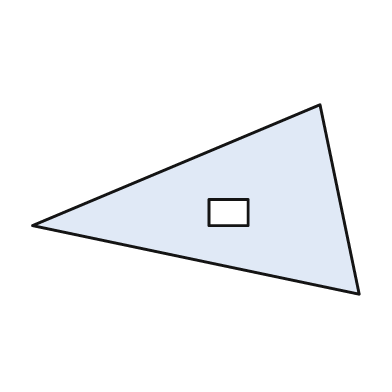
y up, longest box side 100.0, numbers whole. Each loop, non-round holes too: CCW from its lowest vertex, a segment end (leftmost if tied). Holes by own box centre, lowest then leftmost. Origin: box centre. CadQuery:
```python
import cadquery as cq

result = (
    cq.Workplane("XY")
    .moveTo(50.0, -29.0)
    .lineTo(38.0, 29.0)
    .lineTo(-50.0, -8.0)
    .close()
    .moveTo(4.0, -8.0)
    .lineTo(16.0, -8.0)
    .lineTo(16.0, 0.0)
    .lineTo(4.0, 0.0)
    .close()
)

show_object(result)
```